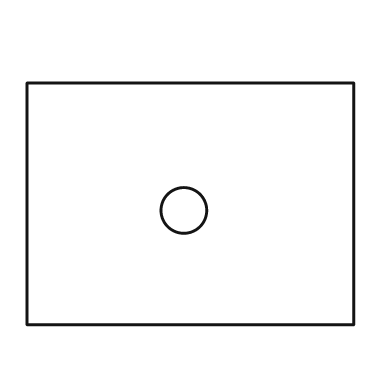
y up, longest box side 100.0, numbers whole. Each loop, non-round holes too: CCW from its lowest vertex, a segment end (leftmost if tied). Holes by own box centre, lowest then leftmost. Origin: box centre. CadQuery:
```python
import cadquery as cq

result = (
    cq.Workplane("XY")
    .moveTo(-50.0, -37.0)
    .lineTo(50.0, -37.0)
    .lineTo(50.0, 37.0)
    .lineTo(-50.0, 37.0)
    .close()
    .moveTo(-2.0, -2.0)
    .circle(7.0)
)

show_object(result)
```